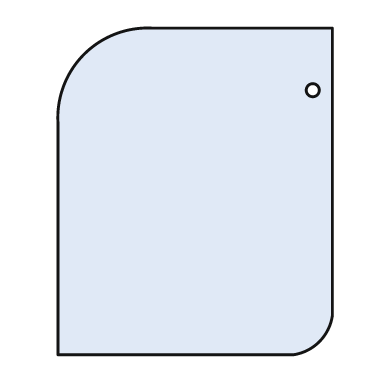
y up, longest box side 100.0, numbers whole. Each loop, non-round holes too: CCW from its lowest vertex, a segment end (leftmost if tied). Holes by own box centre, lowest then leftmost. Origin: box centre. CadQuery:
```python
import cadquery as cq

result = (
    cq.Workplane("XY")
    .moveTo(-42.0, -50.0)
    .lineTo(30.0, -50.0)
    .threePointArc((38.0, -46.0), (42.0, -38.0))
    .lineTo(42.0, 50.0)
    .lineTo(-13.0, 50.0)
    .threePointArc((-34.0, 42.0), (-42.0, 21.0))
    .close()
    .moveTo(36.0, 31.0)
    .circle(2.0)
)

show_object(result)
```